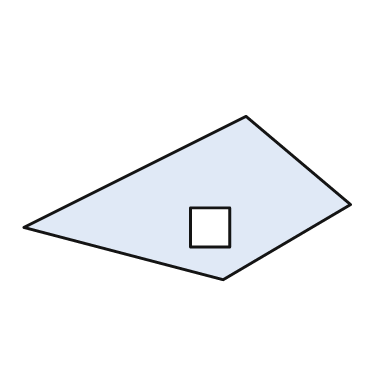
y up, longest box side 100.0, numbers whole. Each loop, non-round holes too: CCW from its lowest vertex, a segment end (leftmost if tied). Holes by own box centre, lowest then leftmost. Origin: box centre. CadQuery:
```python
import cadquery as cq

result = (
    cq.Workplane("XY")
    .moveTo(11.0, -25.0)
    .lineTo(50.0, -2.0)
    .lineTo(18.0, 25.0)
    .lineTo(-50.0, -9.0)
    .close()
    .moveTo(1.0, -15.0)
    .lineTo(13.0, -15.0)
    .lineTo(13.0, -3.0)
    .lineTo(1.0, -3.0)
    .close()
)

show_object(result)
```